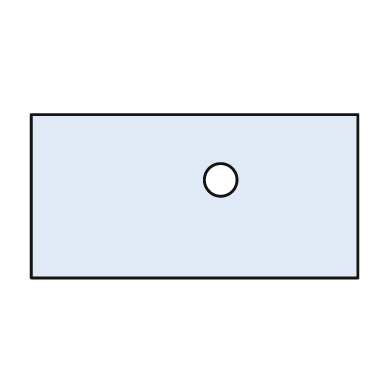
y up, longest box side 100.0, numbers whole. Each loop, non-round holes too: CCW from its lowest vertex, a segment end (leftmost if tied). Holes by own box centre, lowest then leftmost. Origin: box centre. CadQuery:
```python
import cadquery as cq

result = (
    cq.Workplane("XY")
    .moveTo(-50.0, -25.0)
    .lineTo(50.0, -25.0)
    .lineTo(50.0, 25.0)
    .lineTo(-50.0, 25.0)
    .close()
    .moveTo(8.0, 5.0)
    .circle(5.0)
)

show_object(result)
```